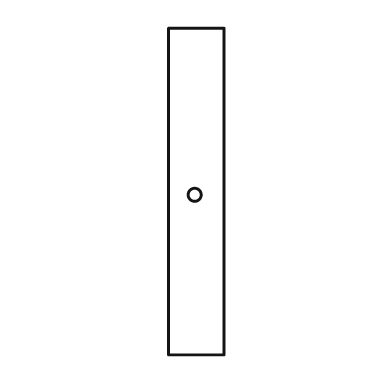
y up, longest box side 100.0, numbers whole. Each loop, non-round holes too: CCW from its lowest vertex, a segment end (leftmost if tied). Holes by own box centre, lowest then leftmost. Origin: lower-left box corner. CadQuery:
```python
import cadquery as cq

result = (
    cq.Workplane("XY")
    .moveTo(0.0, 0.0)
    .lineTo(17.0, 0.0)
    .lineTo(17.0, 100.0)
    .lineTo(0.0, 100.0)
    .close()
    .moveTo(8.0, 49.0)
    .circle(2.0)
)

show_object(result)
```